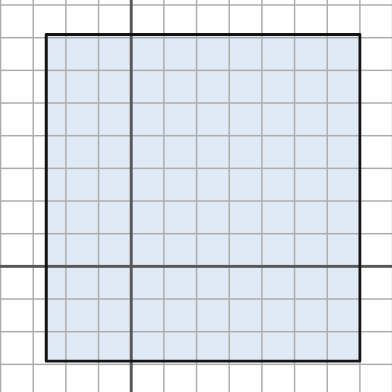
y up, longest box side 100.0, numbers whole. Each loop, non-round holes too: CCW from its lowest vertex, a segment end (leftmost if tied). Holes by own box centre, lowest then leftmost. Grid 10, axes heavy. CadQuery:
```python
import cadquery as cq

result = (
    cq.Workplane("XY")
    .moveTo(-26.0, -29.0)
    .lineTo(70.0, -29.0)
    .lineTo(70.0, 71.0)
    .lineTo(-26.0, 71.0)
    .close()
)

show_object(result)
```